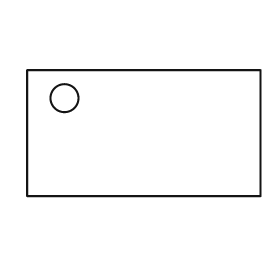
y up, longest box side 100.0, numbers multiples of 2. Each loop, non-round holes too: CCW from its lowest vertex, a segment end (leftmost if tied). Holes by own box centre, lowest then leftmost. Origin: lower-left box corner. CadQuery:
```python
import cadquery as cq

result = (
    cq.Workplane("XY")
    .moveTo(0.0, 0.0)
    .lineTo(100.0, 0.0)
    .lineTo(100.0, 54.0)
    .lineTo(0.0, 54.0)
    .close()
    .moveTo(16.0, 42.0)
    .circle(6.0)
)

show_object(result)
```